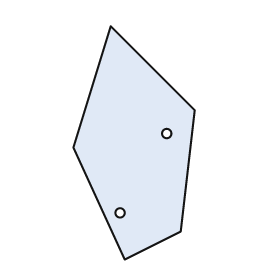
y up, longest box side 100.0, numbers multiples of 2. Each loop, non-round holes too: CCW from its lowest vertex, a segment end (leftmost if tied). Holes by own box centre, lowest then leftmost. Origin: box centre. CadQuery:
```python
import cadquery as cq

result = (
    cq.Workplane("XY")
    .moveTo(-4.0, -50.0)
    .lineTo(20.0, -38.0)
    .lineTo(26.0, 14.0)
    .lineTo(-10.0, 50.0)
    .lineTo(-26.0, -2.0)
    .close()
    .moveTo(-6.0, -30.0)
    .circle(2.0)
    .moveTo(14.0, 4.0)
    .circle(2.0)
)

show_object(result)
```